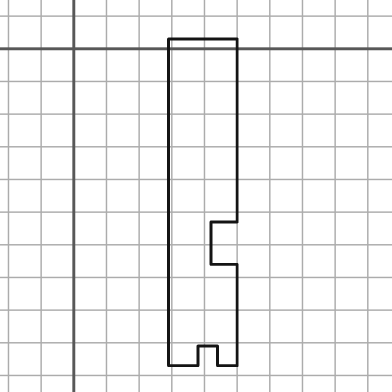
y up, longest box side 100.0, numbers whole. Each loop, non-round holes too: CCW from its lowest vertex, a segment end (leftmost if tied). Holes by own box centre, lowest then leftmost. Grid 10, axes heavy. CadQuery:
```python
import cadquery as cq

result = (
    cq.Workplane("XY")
    .moveTo(29.0, -97.0)
    .lineTo(38.0, -97.0)
    .lineTo(38.0, -91.0)
    .lineTo(44.0, -91.0)
    .lineTo(44.0, -97.0)
    .lineTo(50.0, -97.0)
    .lineTo(50.0, -66.0)
    .lineTo(42.0, -66.0)
    .lineTo(42.0, -53.0)
    .lineTo(50.0, -53.0)
    .lineTo(50.0, 3.0)
    .lineTo(29.0, 3.0)
    .close()
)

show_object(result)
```